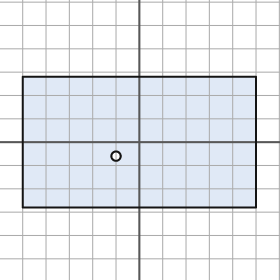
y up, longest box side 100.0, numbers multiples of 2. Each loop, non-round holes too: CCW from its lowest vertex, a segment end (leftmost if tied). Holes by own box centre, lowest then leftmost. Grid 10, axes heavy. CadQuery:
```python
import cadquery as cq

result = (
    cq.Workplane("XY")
    .moveTo(-50.0, -28.0)
    .lineTo(50.0, -28.0)
    .lineTo(50.0, 28.0)
    .lineTo(-50.0, 28.0)
    .close()
    .moveTo(-10.0, -6.0)
    .circle(2.0)
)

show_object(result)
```